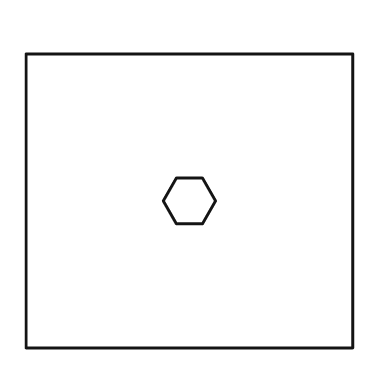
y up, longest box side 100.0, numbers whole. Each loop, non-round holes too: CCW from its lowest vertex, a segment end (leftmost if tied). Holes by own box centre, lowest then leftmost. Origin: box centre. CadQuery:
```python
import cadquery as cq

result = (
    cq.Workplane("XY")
    .moveTo(-50.0, -45.0)
    .lineTo(50.0, -45.0)
    .lineTo(50.0, 45.0)
    .lineTo(-50.0, 45.0)
    .close()
    .moveTo(-4.0, -7.0)
    .lineTo(4.0, -7.0)
    .lineTo(8.0, 0.0)
    .lineTo(4.0, 7.0)
    .lineTo(-4.0, 7.0)
    .lineTo(-8.0, 0.0)
    .close()
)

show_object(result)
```